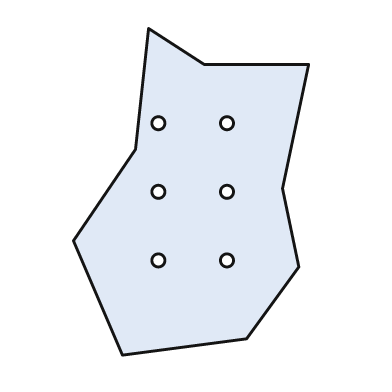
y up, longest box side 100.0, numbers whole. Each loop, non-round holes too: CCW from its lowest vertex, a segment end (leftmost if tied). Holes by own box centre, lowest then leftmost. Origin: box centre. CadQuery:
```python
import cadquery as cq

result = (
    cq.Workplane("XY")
    .moveTo(-21.0, -50.0)
    .lineTo(17.0, -45.0)
    .lineTo(33.0, -23.0)
    .lineTo(28.0, 1.0)
    .lineTo(36.0, 39.0)
    .lineTo(4.0, 39.0)
    .lineTo(-13.0, 50.0)
    .lineTo(-17.0, 13.0)
    .lineTo(-36.0, -15.0)
    .close()
    .moveTo(-10.0, -21.0)
    .circle(2.0)
    .moveTo(11.0, -21.0)
    .circle(2.0)
    .moveTo(-10.0, 0.0)
    .circle(2.0)
    .moveTo(11.0, 0.0)
    .circle(2.0)
    .moveTo(-10.0, 21.0)
    .circle(2.0)
    .moveTo(11.0, 21.0)
    .circle(2.0)
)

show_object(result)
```